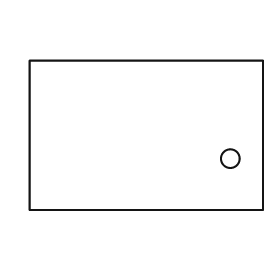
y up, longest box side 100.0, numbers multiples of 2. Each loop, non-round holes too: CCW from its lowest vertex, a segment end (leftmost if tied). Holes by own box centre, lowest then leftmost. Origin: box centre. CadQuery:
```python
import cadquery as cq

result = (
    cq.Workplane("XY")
    .moveTo(-50.0, -32.0)
    .lineTo(50.0, -32.0)
    .lineTo(50.0, 32.0)
    .lineTo(-50.0, 32.0)
    .close()
    .moveTo(36.0, -10.0)
    .circle(4.0)
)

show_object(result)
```